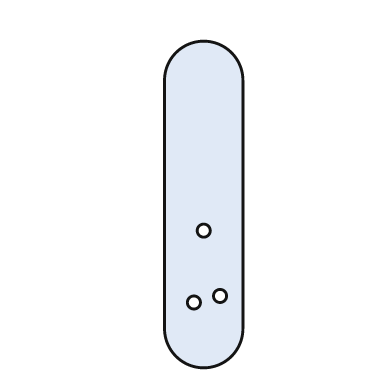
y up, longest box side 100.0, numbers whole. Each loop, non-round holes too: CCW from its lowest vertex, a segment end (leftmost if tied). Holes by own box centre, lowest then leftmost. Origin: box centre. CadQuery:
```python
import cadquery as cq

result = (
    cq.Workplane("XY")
    .moveTo(-12.0, -38.0)
    .threePointArc((0.0, -50.0), (12.0, -38.0))
    .lineTo(12.0, 38.0)
    .threePointArc((0.0, 50.0), (-12.0, 38.0))
    .close()
    .moveTo(-3.0, -30.0)
    .circle(2.0)
    .moveTo(5.0, -28.0)
    .circle(2.0)
    .moveTo(0.0, -8.0)
    .circle(2.0)
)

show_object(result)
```